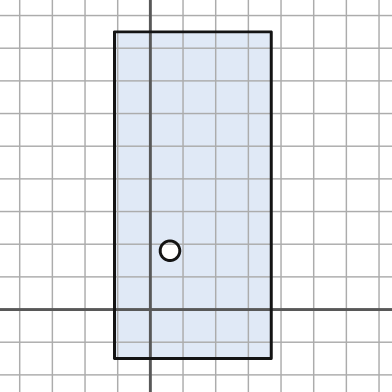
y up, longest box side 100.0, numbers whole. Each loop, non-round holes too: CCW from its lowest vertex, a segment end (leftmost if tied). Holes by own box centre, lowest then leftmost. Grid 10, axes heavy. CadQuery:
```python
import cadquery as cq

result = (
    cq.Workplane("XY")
    .moveTo(-11.0, -15.0)
    .lineTo(37.0, -15.0)
    .lineTo(37.0, 85.0)
    .lineTo(-11.0, 85.0)
    .close()
    .moveTo(6.0, 18.0)
    .circle(3.0)
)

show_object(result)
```